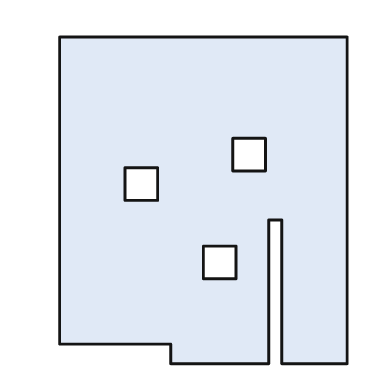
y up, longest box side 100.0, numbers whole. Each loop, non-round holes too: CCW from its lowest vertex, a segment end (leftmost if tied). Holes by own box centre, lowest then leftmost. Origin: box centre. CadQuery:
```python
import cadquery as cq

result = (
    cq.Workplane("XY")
    .moveTo(-10.0, -50.0)
    .lineTo(20.0, -50.0)
    .lineTo(20.0, -6.0)
    .lineTo(24.0, -6.0)
    .lineTo(24.0, -50.0)
    .lineTo(44.0, -50.0)
    .lineTo(44.0, 50.0)
    .lineTo(-44.0, 50.0)
    .lineTo(-44.0, -44.0)
    .lineTo(-10.0, -44.0)
    .close()
    .moveTo(0.0, -24.0)
    .lineTo(10.0, -24.0)
    .lineTo(10.0, -14.0)
    .lineTo(0.0, -14.0)
    .close()
    .moveTo(-24.0, 0.0)
    .lineTo(-14.0, 0.0)
    .lineTo(-14.0, 10.0)
    .lineTo(-24.0, 10.0)
    .close()
    .moveTo(9.0, 9.0)
    .lineTo(19.0, 9.0)
    .lineTo(19.0, 19.0)
    .lineTo(9.0, 19.0)
    .close()
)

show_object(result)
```